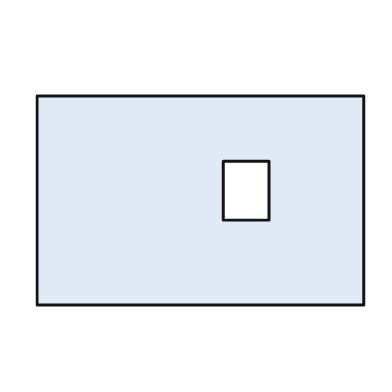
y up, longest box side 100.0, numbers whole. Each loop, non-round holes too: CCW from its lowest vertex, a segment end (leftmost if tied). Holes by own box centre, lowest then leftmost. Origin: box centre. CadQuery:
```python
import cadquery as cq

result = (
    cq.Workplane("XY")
    .moveTo(-50.0, -32.0)
    .lineTo(50.0, -32.0)
    .lineTo(50.0, 32.0)
    .lineTo(-50.0, 32.0)
    .close()
    .moveTo(7.0, -6.0)
    .lineTo(21.0, -6.0)
    .lineTo(21.0, 12.0)
    .lineTo(7.0, 12.0)
    .close()
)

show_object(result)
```